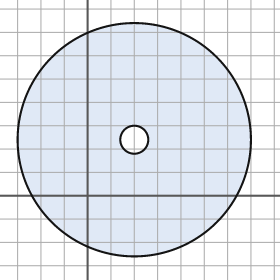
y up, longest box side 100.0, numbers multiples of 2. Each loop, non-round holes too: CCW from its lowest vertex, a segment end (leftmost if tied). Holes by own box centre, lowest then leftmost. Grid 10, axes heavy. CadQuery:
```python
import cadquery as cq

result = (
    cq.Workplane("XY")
    .moveTo(20.0, 24.0)
    .circle(50.0)
    .moveTo(20.0, 24.0)
    .circle(6.0)
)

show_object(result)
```